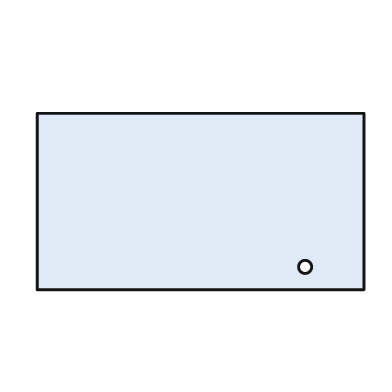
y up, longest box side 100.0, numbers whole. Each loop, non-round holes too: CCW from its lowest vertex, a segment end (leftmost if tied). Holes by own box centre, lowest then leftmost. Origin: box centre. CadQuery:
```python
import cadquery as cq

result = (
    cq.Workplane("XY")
    .moveTo(-50.0, -27.0)
    .lineTo(50.0, -27.0)
    .lineTo(50.0, 27.0)
    .lineTo(-50.0, 27.0)
    .close()
    .moveTo(32.0, -20.0)
    .circle(2.0)
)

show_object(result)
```